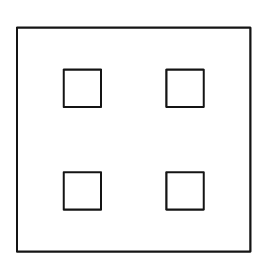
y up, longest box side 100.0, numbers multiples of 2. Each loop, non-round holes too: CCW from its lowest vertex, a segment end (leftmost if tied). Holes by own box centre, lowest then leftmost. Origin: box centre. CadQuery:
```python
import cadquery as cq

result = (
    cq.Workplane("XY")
    .moveTo(-50.0, -48.0)
    .lineTo(50.0, -48.0)
    .lineTo(50.0, 48.0)
    .lineTo(-50.0, 48.0)
    .close()
    .moveTo(-30.0, -30.0)
    .lineTo(-14.0, -30.0)
    .lineTo(-14.0, -14.0)
    .lineTo(-30.0, -14.0)
    .close()
    .moveTo(14.0, -30.0)
    .lineTo(30.0, -30.0)
    .lineTo(30.0, -14.0)
    .lineTo(14.0, -14.0)
    .close()
    .moveTo(-30.0, 14.0)
    .lineTo(-14.0, 14.0)
    .lineTo(-14.0, 30.0)
    .lineTo(-30.0, 30.0)
    .close()
    .moveTo(14.0, 14.0)
    .lineTo(30.0, 14.0)
    .lineTo(30.0, 30.0)
    .lineTo(14.0, 30.0)
    .close()
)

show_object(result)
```